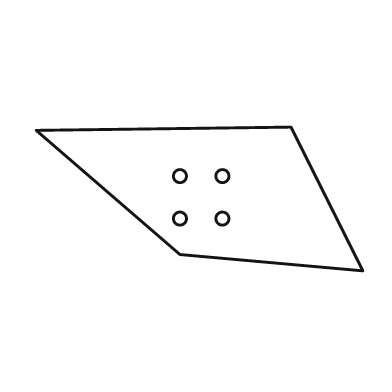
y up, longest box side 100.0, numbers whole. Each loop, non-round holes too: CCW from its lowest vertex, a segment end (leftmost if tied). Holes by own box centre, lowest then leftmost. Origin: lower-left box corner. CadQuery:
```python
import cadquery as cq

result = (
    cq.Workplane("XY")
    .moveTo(100.0, 0.0)
    .lineTo(78.0, 44.0)
    .lineTo(0.0, 43.0)
    .lineTo(44.0, 5.0)
    .close()
    .moveTo(44.0, 16.0)
    .circle(2.0)
    .moveTo(57.0, 16.0)
    .circle(2.0)
    .moveTo(44.0, 29.0)
    .circle(2.0)
    .moveTo(57.0, 29.0)
    .circle(2.0)
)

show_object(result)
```